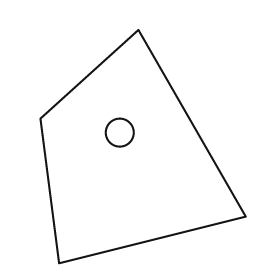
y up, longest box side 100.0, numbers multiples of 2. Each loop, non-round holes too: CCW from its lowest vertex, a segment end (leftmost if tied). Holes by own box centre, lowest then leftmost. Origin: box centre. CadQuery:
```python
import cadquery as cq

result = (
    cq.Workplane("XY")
    .moveTo(-36.0, -50.0)
    .lineTo(44.0, -30.0)
    .lineTo(-2.0, 50.0)
    .lineTo(-44.0, 12.0)
    .close()
    .moveTo(-10.0, 6.0)
    .circle(6.0)
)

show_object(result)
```